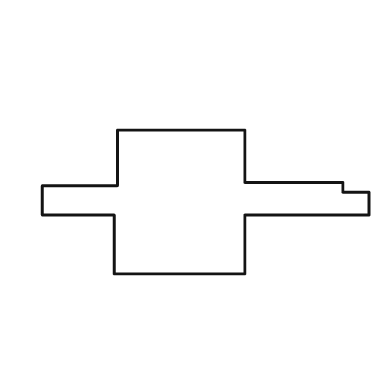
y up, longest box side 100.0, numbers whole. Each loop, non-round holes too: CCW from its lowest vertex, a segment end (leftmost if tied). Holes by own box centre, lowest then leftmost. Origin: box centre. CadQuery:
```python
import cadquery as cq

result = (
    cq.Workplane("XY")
    .moveTo(-28.0, -22.0)
    .lineTo(12.0, -22.0)
    .lineTo(12.0, -4.0)
    .lineTo(50.0, -4.0)
    .lineTo(50.0, 3.0)
    .lineTo(42.0, 3.0)
    .lineTo(42.0, 6.0)
    .lineTo(12.0, 6.0)
    .lineTo(12.0, 22.0)
    .lineTo(-27.0, 22.0)
    .lineTo(-27.0, 5.0)
    .lineTo(-50.0, 5.0)
    .lineTo(-50.0, -4.0)
    .lineTo(-28.0, -4.0)
    .close()
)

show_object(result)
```